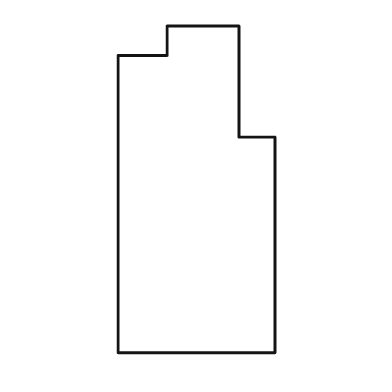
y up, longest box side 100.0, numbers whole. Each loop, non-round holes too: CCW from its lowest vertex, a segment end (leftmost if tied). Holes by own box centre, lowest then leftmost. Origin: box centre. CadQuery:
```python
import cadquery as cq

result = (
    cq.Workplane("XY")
    .moveTo(-24.0, -50.0)
    .lineTo(24.0, -50.0)
    .lineTo(24.0, 16.0)
    .lineTo(13.0, 16.0)
    .lineTo(13.0, 50.0)
    .lineTo(-9.0, 50.0)
    .lineTo(-9.0, 41.0)
    .lineTo(-24.0, 41.0)
    .close()
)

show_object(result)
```